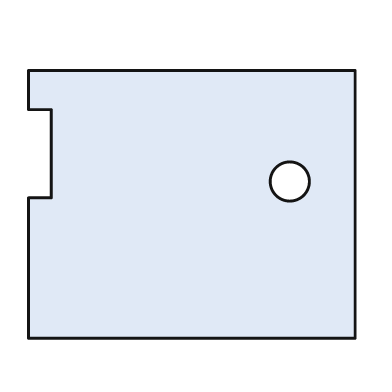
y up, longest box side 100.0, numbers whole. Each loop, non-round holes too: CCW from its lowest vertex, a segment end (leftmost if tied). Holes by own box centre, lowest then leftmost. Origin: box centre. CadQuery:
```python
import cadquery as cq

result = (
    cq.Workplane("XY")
    .moveTo(-50.0, -41.0)
    .lineTo(50.0, -41.0)
    .lineTo(50.0, 41.0)
    .lineTo(-50.0, 41.0)
    .lineTo(-50.0, 29.0)
    .lineTo(-43.0, 29.0)
    .lineTo(-43.0, 2.0)
    .lineTo(-50.0, 2.0)
    .close()
    .moveTo(30.0, 7.0)
    .circle(6.0)
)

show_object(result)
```